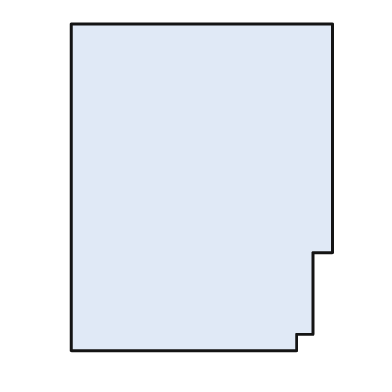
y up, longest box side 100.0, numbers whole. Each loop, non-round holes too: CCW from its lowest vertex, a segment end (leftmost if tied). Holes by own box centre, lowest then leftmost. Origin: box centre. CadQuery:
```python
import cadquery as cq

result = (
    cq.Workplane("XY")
    .moveTo(-40.0, -50.0)
    .lineTo(29.0, -50.0)
    .lineTo(29.0, -45.0)
    .lineTo(34.0, -45.0)
    .lineTo(34.0, -20.0)
    .lineTo(40.0, -20.0)
    .lineTo(40.0, 50.0)
    .lineTo(-40.0, 50.0)
    .close()
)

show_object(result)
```